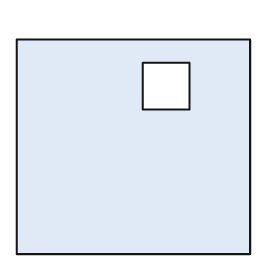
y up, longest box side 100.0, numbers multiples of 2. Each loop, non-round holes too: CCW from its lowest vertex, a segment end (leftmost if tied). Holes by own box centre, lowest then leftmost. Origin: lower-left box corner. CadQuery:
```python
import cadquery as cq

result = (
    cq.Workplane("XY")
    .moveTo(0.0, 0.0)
    .lineTo(100.0, 0.0)
    .lineTo(100.0, 92.0)
    .lineTo(0.0, 92.0)
    .close()
    .moveTo(54.0, 62.0)
    .lineTo(74.0, 62.0)
    .lineTo(74.0, 82.0)
    .lineTo(54.0, 82.0)
    .close()
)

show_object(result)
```